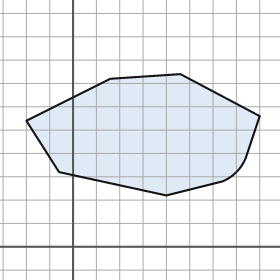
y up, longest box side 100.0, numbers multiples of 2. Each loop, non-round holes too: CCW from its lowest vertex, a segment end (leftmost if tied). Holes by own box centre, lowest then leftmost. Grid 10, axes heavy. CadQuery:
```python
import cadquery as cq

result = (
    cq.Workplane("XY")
    .moveTo(40.0, 22.0)
    .lineTo(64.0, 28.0)
    .threePointArc((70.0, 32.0), (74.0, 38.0))
    .lineTo(80.0, 56.0)
    .lineTo(46.0, 74.0)
    .lineTo(16.0, 72.0)
    .lineTo(-20.0, 54.0)
    .lineTo(-6.0, 32.0)
    .close()
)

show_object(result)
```